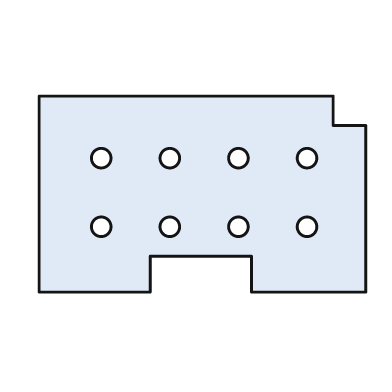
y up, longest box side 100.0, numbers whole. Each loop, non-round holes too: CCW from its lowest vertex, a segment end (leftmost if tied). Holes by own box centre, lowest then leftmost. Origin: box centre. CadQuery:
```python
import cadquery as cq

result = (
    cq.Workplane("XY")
    .moveTo(-50.0, -30.0)
    .lineTo(-16.0, -30.0)
    .lineTo(-16.0, -19.0)
    .lineTo(15.0, -19.0)
    .lineTo(15.0, -30.0)
    .lineTo(50.0, -30.0)
    .lineTo(50.0, 21.0)
    .lineTo(40.0, 21.0)
    .lineTo(40.0, 30.0)
    .lineTo(-50.0, 30.0)
    .close()
    .moveTo(-31.0, -10.0)
    .circle(3.0)
    .moveTo(-10.0, -10.0)
    .circle(3.0)
    .moveTo(11.0, -10.0)
    .circle(3.0)
    .moveTo(32.0, -10.0)
    .circle(3.0)
    .moveTo(-31.0, 11.0)
    .circle(3.0)
    .moveTo(-10.0, 11.0)
    .circle(3.0)
    .moveTo(11.0, 11.0)
    .circle(3.0)
    .moveTo(32.0, 11.0)
    .circle(3.0)
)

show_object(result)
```